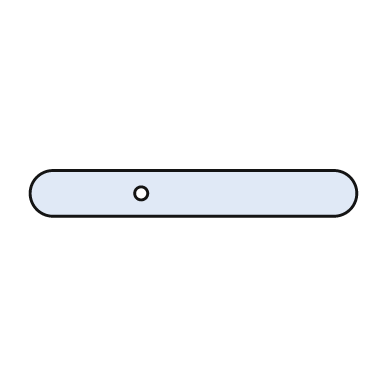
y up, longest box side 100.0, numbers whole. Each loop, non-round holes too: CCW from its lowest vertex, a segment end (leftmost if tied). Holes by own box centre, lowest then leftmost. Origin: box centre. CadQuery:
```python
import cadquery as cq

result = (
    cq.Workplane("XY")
    .moveTo(-43.0, -7.0)
    .lineTo(43.0, -7.0)
    .threePointArc((50.0, 0.0), (43.0, 7.0))
    .lineTo(-43.0, 7.0)
    .threePointArc((-50.0, 0.0), (-43.0, -7.0))
    .close()
    .moveTo(-16.0, 0.0)
    .circle(2.0)
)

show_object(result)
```